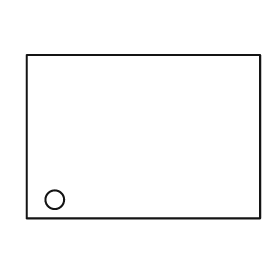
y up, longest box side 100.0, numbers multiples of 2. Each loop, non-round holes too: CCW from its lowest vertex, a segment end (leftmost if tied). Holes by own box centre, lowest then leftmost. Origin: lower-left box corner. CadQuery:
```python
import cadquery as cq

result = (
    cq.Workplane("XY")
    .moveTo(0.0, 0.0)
    .lineTo(100.0, 0.0)
    .lineTo(100.0, 70.0)
    .lineTo(0.0, 70.0)
    .close()
    .moveTo(12.0, 8.0)
    .circle(4.0)
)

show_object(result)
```